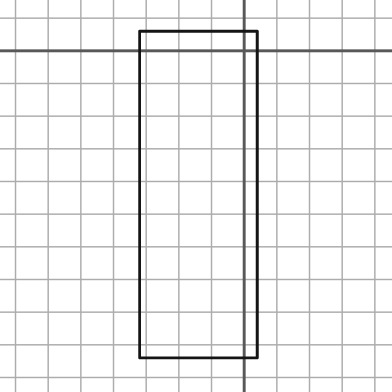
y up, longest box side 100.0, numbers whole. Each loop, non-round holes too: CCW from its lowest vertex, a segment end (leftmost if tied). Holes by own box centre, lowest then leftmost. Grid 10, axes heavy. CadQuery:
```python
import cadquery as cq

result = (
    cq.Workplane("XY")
    .moveTo(-32.0, -94.0)
    .lineTo(4.0, -94.0)
    .lineTo(4.0, 6.0)
    .lineTo(-32.0, 6.0)
    .close()
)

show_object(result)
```